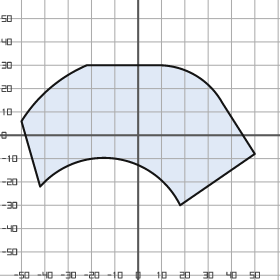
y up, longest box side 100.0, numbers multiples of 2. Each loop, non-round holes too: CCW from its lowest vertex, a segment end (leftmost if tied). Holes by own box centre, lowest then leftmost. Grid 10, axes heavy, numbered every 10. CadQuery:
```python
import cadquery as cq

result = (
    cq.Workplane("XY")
    .moveTo(18.0, -30.0)
    .lineTo(50.0, -8.0)
    .lineTo(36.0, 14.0)
    .threePointArc((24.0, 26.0), (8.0, 30.0))
    .lineTo(-22.0, 30.0)
    .threePointArc((-38.0, 20.0), (-50.0, 6.0))
    .lineTo(-42.0, -22.0)
    .threePointArc((-10.0, -10.0), (18.0, -30.0))
    .close()
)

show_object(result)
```